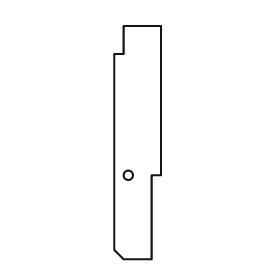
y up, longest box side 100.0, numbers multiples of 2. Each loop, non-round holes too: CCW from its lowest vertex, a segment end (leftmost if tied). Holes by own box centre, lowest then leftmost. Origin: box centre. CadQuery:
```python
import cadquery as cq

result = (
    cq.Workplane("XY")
    .moveTo(-6.0, -50.0)
    .lineTo(6.0, -50.0)
    .lineTo(6.0, -14.0)
    .lineTo(10.0, -14.0)
    .lineTo(10.0, 50.0)
    .lineTo(-6.0, 50.0)
    .lineTo(-6.0, 38.0)
    .lineTo(-10.0, 38.0)
    .lineTo(-10.0, -46.0)
    .close()
    .moveTo(-4.0, -14.0)
    .circle(2.0)
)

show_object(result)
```